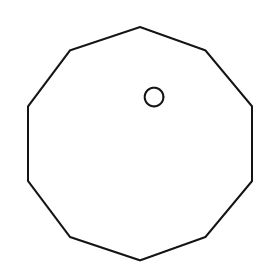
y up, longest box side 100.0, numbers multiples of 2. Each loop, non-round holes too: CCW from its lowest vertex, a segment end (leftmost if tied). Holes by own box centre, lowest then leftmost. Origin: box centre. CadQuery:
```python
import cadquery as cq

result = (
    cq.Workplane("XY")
    .moveTo(0.0, -50.0)
    .lineTo(28.0, -40.0)
    .lineTo(48.0, -16.0)
    .lineTo(48.0, 16.0)
    .lineTo(28.0, 40.0)
    .lineTo(0.0, 50.0)
    .lineTo(-30.0, 40.0)
    .lineTo(-48.0, 16.0)
    .lineTo(-48.0, -16.0)
    .lineTo(-30.0, -40.0)
    .close()
    .moveTo(6.0, 20.0)
    .circle(4.0)
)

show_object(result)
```